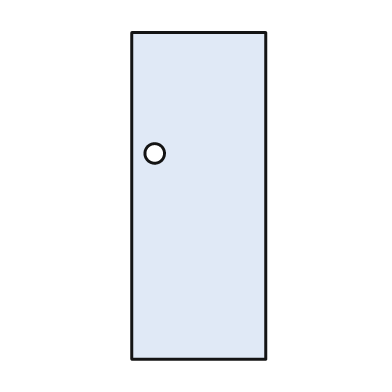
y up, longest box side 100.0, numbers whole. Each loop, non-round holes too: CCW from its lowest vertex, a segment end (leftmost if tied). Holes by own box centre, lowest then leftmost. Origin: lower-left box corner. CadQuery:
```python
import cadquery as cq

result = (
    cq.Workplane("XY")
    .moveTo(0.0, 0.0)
    .lineTo(41.0, 0.0)
    .lineTo(41.0, 100.0)
    .lineTo(0.0, 100.0)
    .close()
    .moveTo(7.0, 63.0)
    .circle(3.0)
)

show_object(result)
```